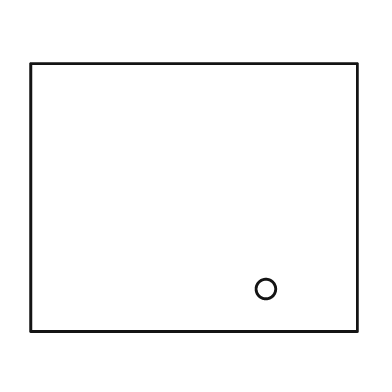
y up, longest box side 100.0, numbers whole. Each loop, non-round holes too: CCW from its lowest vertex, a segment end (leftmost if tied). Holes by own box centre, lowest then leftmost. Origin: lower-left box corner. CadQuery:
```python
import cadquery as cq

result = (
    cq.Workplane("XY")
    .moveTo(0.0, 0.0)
    .lineTo(100.0, 0.0)
    .lineTo(100.0, 82.0)
    .lineTo(0.0, 82.0)
    .close()
    .moveTo(72.0, 13.0)
    .circle(3.0)
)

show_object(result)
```